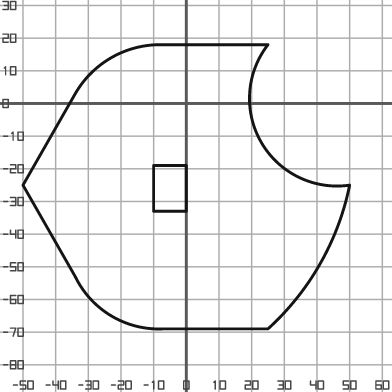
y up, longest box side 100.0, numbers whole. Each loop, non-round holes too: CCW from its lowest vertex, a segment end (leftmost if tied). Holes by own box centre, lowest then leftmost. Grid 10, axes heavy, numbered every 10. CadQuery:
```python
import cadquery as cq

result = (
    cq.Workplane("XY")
    .moveTo(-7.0, -69.0)
    .lineTo(25.0, -69.0)
    .threePointArc((41.0, -49.0), (50.0, -25.0))
    .threePointArc((23.0, -12.0), (25.0, 18.0))
    .lineTo(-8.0, 18.0)
    .threePointArc((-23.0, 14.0), (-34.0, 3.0))
    .lineTo(-50.0, -25.0)
    .lineTo(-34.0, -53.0)
    .threePointArc((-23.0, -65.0), (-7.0, -69.0))
    .close()
    .moveTo(-10.0, -33.0)
    .lineTo(0.0, -33.0)
    .lineTo(0.0, -19.0)
    .lineTo(-10.0, -19.0)
    .close()
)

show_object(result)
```